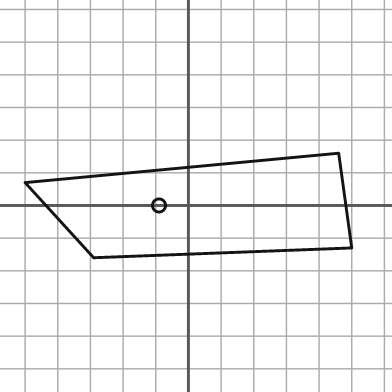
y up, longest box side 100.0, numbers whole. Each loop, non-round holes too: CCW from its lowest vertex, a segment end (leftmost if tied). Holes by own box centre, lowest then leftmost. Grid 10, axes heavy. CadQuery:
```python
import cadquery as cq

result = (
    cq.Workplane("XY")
    .moveTo(-29.0, -16.0)
    .lineTo(50.0, -13.0)
    .lineTo(46.0, 16.0)
    .lineTo(-50.0, 7.0)
    .close()
    .moveTo(-9.0, 0.0)
    .circle(2.0)
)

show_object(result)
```